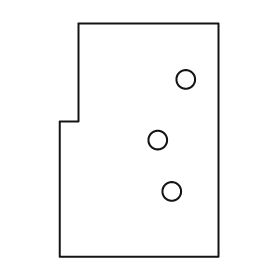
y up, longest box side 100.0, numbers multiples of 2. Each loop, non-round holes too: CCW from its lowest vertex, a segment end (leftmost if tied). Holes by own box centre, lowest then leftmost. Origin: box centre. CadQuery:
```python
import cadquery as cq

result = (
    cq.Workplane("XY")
    .moveTo(-34.0, -50.0)
    .lineTo(34.0, -50.0)
    .lineTo(34.0, 50.0)
    .lineTo(-26.0, 50.0)
    .lineTo(-26.0, 8.0)
    .lineTo(-34.0, 8.0)
    .close()
    .moveTo(14.0, -22.0)
    .circle(4.0)
    .moveTo(8.0, 0.0)
    .circle(4.0)
    .moveTo(20.0, 26.0)
    .circle(4.0)
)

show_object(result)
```